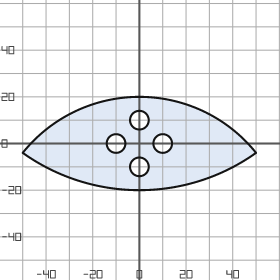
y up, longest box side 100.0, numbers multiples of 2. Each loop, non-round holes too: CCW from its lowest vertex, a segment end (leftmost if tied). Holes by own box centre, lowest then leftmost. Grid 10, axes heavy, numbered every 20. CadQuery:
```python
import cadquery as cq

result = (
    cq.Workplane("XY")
    .moveTo(-50.0, -4.0)
    .threePointArc((0.0, -20.0), (50.0, -4.0))
    .threePointArc((0.0, 20.0), (-50.0, -4.0))
    .close()
    .moveTo(0.0, -10.0)
    .circle(4.0)
    .moveTo(-10.0, 0.0)
    .circle(4.0)
    .moveTo(10.0, 0.0)
    .circle(4.0)
    .moveTo(0.0, 10.0)
    .circle(4.0)
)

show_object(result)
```